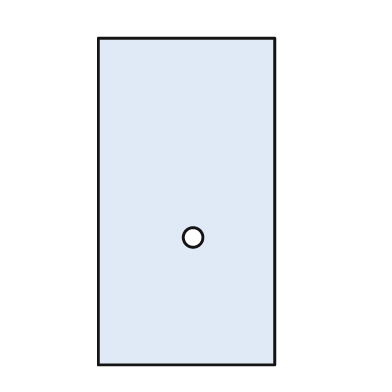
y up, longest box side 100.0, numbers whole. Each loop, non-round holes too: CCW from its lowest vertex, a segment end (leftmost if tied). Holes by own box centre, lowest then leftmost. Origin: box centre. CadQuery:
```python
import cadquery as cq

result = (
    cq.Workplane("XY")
    .moveTo(-27.0, -50.0)
    .lineTo(27.0, -50.0)
    .lineTo(27.0, 50.0)
    .lineTo(-27.0, 50.0)
    .close()
    .moveTo(2.0, -11.0)
    .circle(3.0)
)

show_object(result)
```